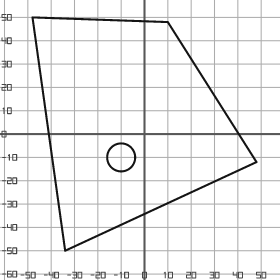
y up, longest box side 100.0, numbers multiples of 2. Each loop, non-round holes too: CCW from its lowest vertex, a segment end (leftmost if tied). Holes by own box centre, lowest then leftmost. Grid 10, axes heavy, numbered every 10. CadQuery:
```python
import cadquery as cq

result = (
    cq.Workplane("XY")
    .moveTo(-34.0, -50.0)
    .lineTo(48.0, -12.0)
    .lineTo(10.0, 48.0)
    .lineTo(-48.0, 50.0)
    .close()
    .moveTo(-10.0, -10.0)
    .circle(6.0)
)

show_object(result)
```